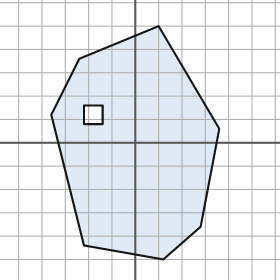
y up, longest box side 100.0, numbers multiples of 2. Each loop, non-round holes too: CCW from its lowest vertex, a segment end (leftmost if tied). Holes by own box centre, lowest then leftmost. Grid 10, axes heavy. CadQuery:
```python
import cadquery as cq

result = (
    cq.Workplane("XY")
    .moveTo(12.0, -50.0)
    .lineTo(28.0, -36.0)
    .lineTo(36.0, 6.0)
    .lineTo(10.0, 50.0)
    .lineTo(-24.0, 36.0)
    .lineTo(-36.0, 12.0)
    .lineTo(-22.0, -44.0)
    .close()
    .moveTo(-22.0, 8.0)
    .lineTo(-14.0, 8.0)
    .lineTo(-14.0, 16.0)
    .lineTo(-22.0, 16.0)
    .close()
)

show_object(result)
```